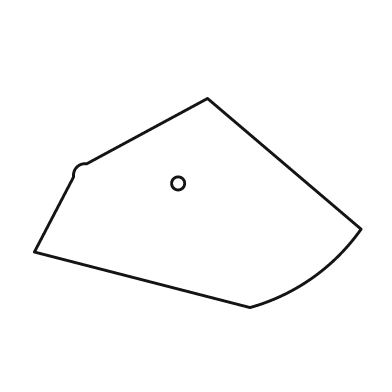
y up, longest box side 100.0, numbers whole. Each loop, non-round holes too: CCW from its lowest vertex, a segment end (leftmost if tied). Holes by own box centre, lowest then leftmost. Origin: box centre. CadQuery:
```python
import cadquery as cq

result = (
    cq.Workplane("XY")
    .moveTo(16.0, -32.0)
    .threePointArc((35.0, -23.0), (50.0, -8.0))
    .lineTo(3.0, 32.0)
    .lineTo(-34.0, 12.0)
    .threePointArc((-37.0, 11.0), (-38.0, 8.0))
    .lineTo(-50.0, -15.0)
    .close()
    .moveTo(-6.0, 6.0)
    .circle(2.0)
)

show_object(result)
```